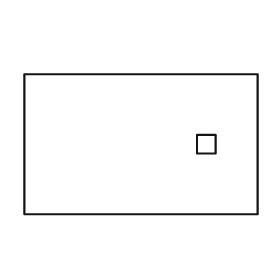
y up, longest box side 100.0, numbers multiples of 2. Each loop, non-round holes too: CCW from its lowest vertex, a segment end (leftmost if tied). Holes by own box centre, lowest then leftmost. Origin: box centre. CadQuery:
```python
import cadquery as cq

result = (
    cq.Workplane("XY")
    .moveTo(-50.0, -30.0)
    .lineTo(50.0, -30.0)
    .lineTo(50.0, 30.0)
    .lineTo(-50.0, 30.0)
    .close()
    .moveTo(24.0, -4.0)
    .lineTo(32.0, -4.0)
    .lineTo(32.0, 4.0)
    .lineTo(24.0, 4.0)
    .close()
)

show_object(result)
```